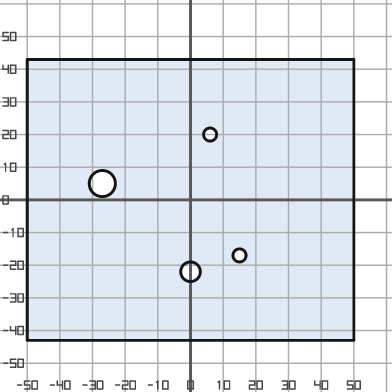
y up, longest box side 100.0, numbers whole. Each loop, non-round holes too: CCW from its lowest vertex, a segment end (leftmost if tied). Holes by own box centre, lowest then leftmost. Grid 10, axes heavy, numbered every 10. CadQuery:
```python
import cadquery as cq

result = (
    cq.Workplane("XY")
    .moveTo(-50.0, -43.0)
    .lineTo(50.0, -43.0)
    .lineTo(50.0, 43.0)
    .lineTo(-50.0, 43.0)
    .close()
    .moveTo(0.0, -22.0)
    .circle(3.0)
    .moveTo(15.0, -17.0)
    .circle(2.0)
    .moveTo(-27.0, 5.0)
    .circle(4.0)
    .moveTo(6.0, 20.0)
    .circle(2.0)
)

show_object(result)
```